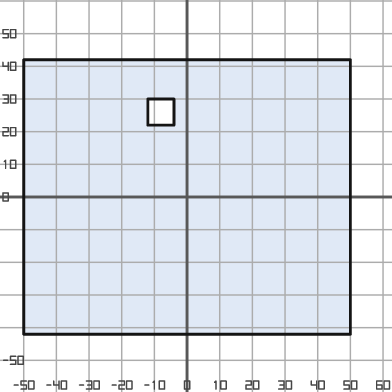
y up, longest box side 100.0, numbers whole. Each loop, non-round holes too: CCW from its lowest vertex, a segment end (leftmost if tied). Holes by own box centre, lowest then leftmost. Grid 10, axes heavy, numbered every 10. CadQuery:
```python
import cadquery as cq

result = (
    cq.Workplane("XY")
    .moveTo(-50.0, -42.0)
    .lineTo(50.0, -42.0)
    .lineTo(50.0, 42.0)
    .lineTo(-50.0, 42.0)
    .close()
    .moveTo(-12.0, 22.0)
    .lineTo(-4.0, 22.0)
    .lineTo(-4.0, 30.0)
    .lineTo(-12.0, 30.0)
    .close()
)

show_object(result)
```